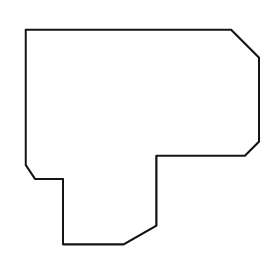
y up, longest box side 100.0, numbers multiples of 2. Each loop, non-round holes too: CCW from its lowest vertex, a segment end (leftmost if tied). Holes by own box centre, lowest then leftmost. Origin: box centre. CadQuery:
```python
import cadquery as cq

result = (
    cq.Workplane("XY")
    .moveTo(-34.0, -46.0)
    .lineTo(-8.0, -46.0)
    .lineTo(6.0, -38.0)
    .lineTo(6.0, -8.0)
    .lineTo(44.0, -8.0)
    .lineTo(50.0, -2.0)
    .lineTo(50.0, 34.0)
    .lineTo(38.0, 46.0)
    .lineTo(-50.0, 46.0)
    .lineTo(-50.0, -12.0)
    .lineTo(-46.0, -18.0)
    .lineTo(-34.0, -18.0)
    .close()
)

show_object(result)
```